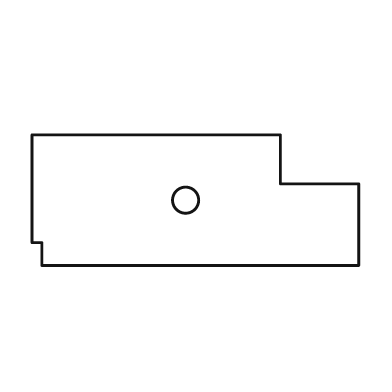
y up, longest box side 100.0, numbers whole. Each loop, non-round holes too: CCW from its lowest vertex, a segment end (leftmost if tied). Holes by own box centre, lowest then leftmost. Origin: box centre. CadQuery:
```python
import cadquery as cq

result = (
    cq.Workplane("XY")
    .moveTo(-47.0, -20.0)
    .lineTo(50.0, -20.0)
    .lineTo(50.0, 5.0)
    .lineTo(26.0, 5.0)
    .lineTo(26.0, 20.0)
    .lineTo(-50.0, 20.0)
    .lineTo(-50.0, -13.0)
    .lineTo(-47.0, -13.0)
    .close()
    .moveTo(-3.0, 0.0)
    .circle(4.0)
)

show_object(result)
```